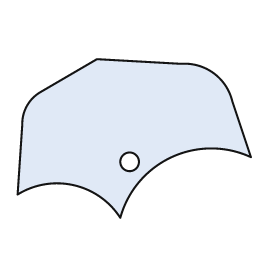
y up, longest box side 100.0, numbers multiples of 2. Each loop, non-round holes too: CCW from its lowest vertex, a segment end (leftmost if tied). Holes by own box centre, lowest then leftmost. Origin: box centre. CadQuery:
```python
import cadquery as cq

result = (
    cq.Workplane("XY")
    .moveTo(-6.0, -34.0)
    .threePointArc((16.0, -8.0), (50.0, -8.0))
    .lineTo(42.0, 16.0)
    .threePointArc((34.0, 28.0), (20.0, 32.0))
    .lineTo(-16.0, 34.0)
    .lineTo(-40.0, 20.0)
    .threePointArc((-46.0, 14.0), (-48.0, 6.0))
    .lineTo(-50.0, -24.0)
    .threePointArc((-26.0, -20.0), (-6.0, -34.0))
    .close()
    .moveTo(-2.0, -10.0)
    .circle(4.0)
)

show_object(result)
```